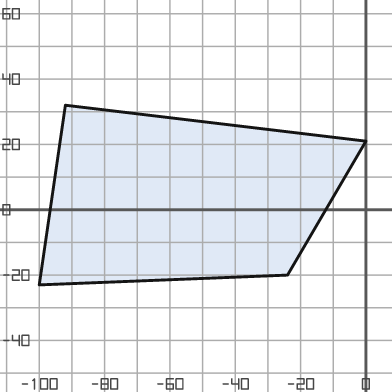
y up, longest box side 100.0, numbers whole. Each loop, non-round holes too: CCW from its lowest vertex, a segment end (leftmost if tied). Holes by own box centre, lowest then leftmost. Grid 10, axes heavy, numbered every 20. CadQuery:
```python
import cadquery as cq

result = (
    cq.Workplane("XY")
    .moveTo(-100.0, -23.0)
    .lineTo(-24.0, -20.0)
    .lineTo(0.0, 21.0)
    .lineTo(-92.0, 32.0)
    .close()
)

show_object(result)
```